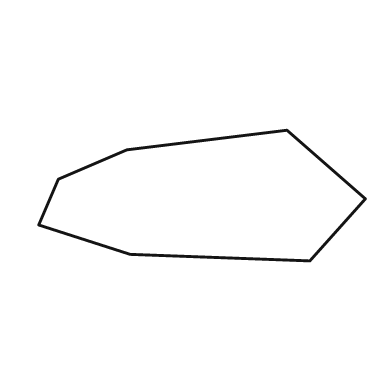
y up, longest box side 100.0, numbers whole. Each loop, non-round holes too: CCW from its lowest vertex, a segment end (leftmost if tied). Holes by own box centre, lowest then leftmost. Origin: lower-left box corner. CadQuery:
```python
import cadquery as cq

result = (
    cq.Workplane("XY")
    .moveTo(83.0, 0.0)
    .lineTo(100.0, 19.0)
    .lineTo(76.0, 40.0)
    .lineTo(27.0, 34.0)
    .lineTo(6.0, 25.0)
    .lineTo(0.0, 11.0)
    .lineTo(28.0, 2.0)
    .close()
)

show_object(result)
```